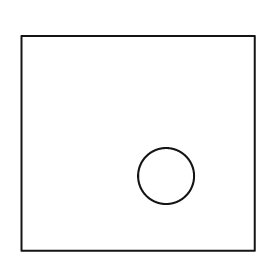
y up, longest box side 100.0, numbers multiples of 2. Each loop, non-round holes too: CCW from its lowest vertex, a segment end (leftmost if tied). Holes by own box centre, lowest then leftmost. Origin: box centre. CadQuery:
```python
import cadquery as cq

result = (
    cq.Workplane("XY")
    .moveTo(-50.0, -46.0)
    .lineTo(50.0, -46.0)
    .lineTo(50.0, 46.0)
    .lineTo(-50.0, 46.0)
    .close()
    .moveTo(12.0, -14.0)
    .circle(12.0)
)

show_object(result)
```